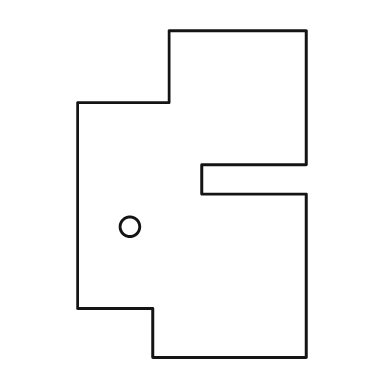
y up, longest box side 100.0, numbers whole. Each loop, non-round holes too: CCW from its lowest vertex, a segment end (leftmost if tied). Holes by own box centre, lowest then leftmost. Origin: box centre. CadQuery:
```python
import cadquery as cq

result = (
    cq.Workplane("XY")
    .moveTo(-12.0, -50.0)
    .lineTo(35.0, -50.0)
    .lineTo(35.0, 0.0)
    .lineTo(3.0, 0.0)
    .lineTo(3.0, 9.0)
    .lineTo(35.0, 9.0)
    .lineTo(35.0, 50.0)
    .lineTo(-7.0, 50.0)
    .lineTo(-7.0, 28.0)
    .lineTo(-35.0, 28.0)
    .lineTo(-35.0, -35.0)
    .lineTo(-12.0, -35.0)
    .close()
    .moveTo(-19.0, -10.0)
    .circle(3.0)
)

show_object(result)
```